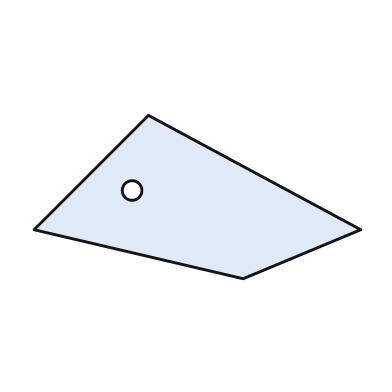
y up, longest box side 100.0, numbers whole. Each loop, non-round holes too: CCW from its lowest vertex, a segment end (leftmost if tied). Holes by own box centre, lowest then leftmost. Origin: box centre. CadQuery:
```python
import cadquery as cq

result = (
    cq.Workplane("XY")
    .moveTo(14.0, -25.0)
    .lineTo(50.0, -10.0)
    .lineTo(-15.0, 25.0)
    .lineTo(-50.0, -10.0)
    .close()
    .moveTo(-20.0, 2.0)
    .circle(3.0)
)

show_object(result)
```